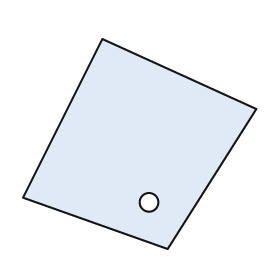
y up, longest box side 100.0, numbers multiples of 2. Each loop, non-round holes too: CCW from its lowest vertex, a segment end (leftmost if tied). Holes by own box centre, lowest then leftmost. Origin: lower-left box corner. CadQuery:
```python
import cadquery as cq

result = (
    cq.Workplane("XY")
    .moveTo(62.0, 0.0)
    .lineTo(100.0, 60.0)
    .lineTo(34.0, 90.0)
    .lineTo(0.0, 22.0)
    .close()
    .moveTo(54.0, 20.0)
    .circle(4.0)
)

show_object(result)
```